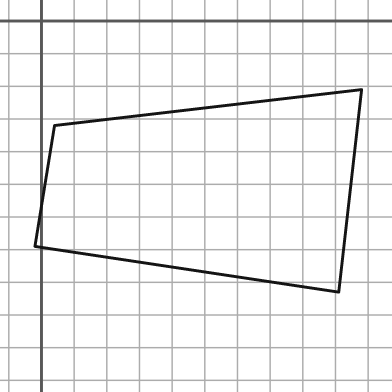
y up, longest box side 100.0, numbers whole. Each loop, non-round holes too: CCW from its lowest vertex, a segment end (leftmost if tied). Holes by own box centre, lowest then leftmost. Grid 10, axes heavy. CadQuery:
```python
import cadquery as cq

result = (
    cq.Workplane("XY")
    .moveTo(91.0, -83.0)
    .lineTo(98.0, -21.0)
    .lineTo(4.0, -32.0)
    .lineTo(-2.0, -69.0)
    .close()
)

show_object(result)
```